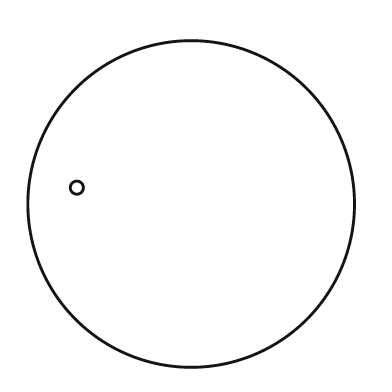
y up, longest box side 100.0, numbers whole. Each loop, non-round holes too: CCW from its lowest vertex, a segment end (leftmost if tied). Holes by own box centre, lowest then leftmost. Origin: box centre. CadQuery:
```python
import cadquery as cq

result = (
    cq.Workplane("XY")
    .moveTo(0.0, 0.0)
    .circle(50.0)
    .moveTo(-35.0, 5.0)
    .circle(2.0)
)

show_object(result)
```